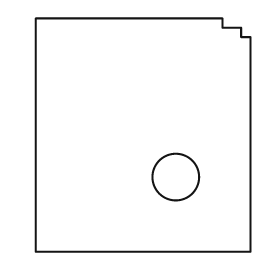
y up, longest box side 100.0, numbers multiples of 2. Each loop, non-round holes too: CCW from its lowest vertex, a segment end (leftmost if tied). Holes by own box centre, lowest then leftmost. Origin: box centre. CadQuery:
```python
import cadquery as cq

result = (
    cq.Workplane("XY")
    .moveTo(-46.0, -50.0)
    .lineTo(46.0, -50.0)
    .lineTo(46.0, 42.0)
    .lineTo(42.0, 42.0)
    .lineTo(42.0, 46.0)
    .lineTo(34.0, 46.0)
    .lineTo(34.0, 50.0)
    .lineTo(-46.0, 50.0)
    .close()
    .moveTo(14.0, -18.0)
    .circle(10.0)
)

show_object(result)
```